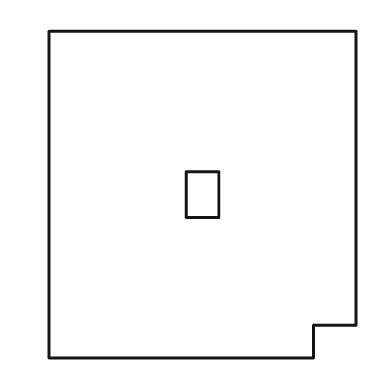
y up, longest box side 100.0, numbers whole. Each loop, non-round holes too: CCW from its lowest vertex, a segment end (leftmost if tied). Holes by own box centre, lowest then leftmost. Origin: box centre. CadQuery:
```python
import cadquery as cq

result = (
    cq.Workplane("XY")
    .moveTo(-47.0, -50.0)
    .lineTo(34.0, -50.0)
    .lineTo(34.0, -40.0)
    .lineTo(47.0, -40.0)
    .lineTo(47.0, 50.0)
    .lineTo(-47.0, 50.0)
    .close()
    .moveTo(-5.0, -7.0)
    .lineTo(5.0, -7.0)
    .lineTo(5.0, 7.0)
    .lineTo(-5.0, 7.0)
    .close()
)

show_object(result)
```